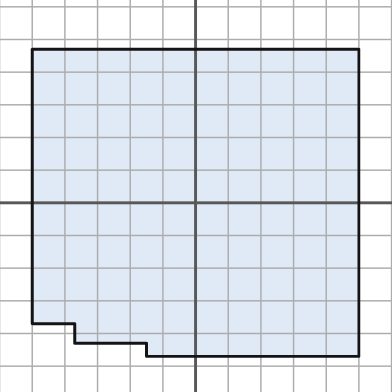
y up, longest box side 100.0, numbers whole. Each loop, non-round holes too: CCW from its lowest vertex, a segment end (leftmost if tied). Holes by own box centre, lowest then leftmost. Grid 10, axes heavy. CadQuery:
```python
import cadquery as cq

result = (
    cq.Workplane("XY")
    .moveTo(-15.0, -47.0)
    .lineTo(50.0, -47.0)
    .lineTo(50.0, 47.0)
    .lineTo(-50.0, 47.0)
    .lineTo(-50.0, -37.0)
    .lineTo(-37.0, -37.0)
    .lineTo(-37.0, -43.0)
    .lineTo(-15.0, -43.0)
    .close()
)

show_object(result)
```